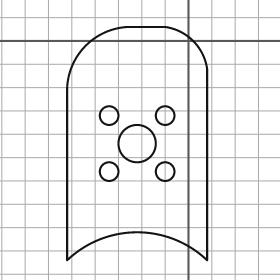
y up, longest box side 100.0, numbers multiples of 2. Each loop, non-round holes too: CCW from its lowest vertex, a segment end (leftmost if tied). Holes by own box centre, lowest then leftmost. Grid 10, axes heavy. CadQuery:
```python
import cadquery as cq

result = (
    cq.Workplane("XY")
    .moveTo(-52.0, -94.0)
    .threePointArc((-22.0, -82.0), (8.0, -94.0))
    .lineTo(8.0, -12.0)
    .threePointArc((2.0, 0.0), (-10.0, 6.0))
    .lineTo(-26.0, 6.0)
    .threePointArc((-44.0, -2.0), (-52.0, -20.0))
    .close()
    .moveTo(-34.0, -56.0)
    .circle(4.0)
    .moveTo(-10.0, -56.0)
    .circle(4.0)
    .moveTo(-22.0, -44.0)
    .circle(8.0)
    .moveTo(-34.0, -32.0)
    .circle(4.0)
    .moveTo(-10.0, -32.0)
    .circle(4.0)
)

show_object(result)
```